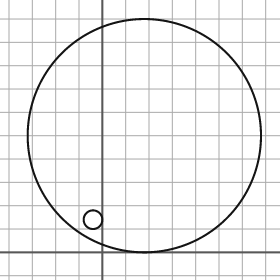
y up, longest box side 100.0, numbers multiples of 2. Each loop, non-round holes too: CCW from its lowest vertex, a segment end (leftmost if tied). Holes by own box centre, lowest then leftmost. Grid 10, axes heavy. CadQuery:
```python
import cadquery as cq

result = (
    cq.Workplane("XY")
    .moveTo(18.0, 50.0)
    .circle(50.0)
    .moveTo(-4.0, 14.0)
    .circle(4.0)
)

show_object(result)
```